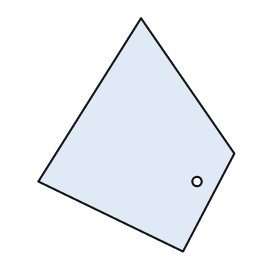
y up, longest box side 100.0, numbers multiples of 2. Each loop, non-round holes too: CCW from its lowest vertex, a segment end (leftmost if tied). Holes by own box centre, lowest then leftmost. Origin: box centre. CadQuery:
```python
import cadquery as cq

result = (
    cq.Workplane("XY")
    .moveTo(20.0, -50.0)
    .lineTo(42.0, -8.0)
    .lineTo(2.0, 50.0)
    .lineTo(-42.0, -20.0)
    .close()
    .moveTo(26.0, -20.0)
    .circle(2.0)
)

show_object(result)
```